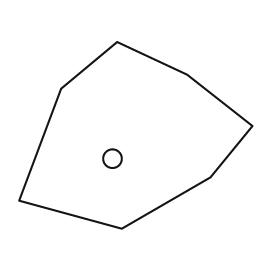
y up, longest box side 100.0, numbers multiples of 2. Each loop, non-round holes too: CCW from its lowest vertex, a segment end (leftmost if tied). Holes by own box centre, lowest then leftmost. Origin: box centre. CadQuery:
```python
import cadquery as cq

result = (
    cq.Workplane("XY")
    .moveTo(-6.0, -40.0)
    .lineTo(32.0, -18.0)
    .lineTo(50.0, 4.0)
    .lineTo(22.0, 26.0)
    .lineTo(-8.0, 40.0)
    .lineTo(-32.0, 20.0)
    .lineTo(-50.0, -28.0)
    .close()
    .moveTo(-10.0, -10.0)
    .circle(4.0)
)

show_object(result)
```